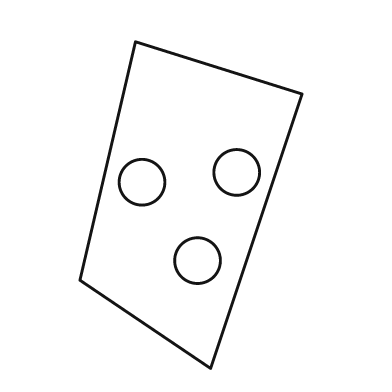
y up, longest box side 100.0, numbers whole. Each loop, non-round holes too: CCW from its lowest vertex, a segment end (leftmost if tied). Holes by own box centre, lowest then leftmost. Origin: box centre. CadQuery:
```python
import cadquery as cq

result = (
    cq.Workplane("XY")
    .moveTo(6.0, -50.0)
    .lineTo(34.0, 34.0)
    .lineTo(-17.0, 50.0)
    .lineTo(-34.0, -23.0)
    .close()
    .moveTo(2.0, -17.0)
    .circle(7.0)
    .moveTo(-15.0, 7.0)
    .circle(7.0)
    .moveTo(14.0, 10.0)
    .circle(7.0)
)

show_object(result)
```